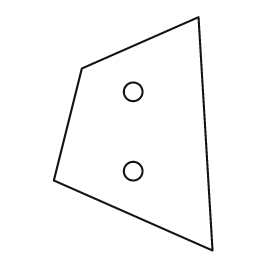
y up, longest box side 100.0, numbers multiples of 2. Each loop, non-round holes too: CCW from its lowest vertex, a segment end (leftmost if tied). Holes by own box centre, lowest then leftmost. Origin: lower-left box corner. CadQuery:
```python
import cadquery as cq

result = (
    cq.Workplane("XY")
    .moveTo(68.0, 0.0)
    .lineTo(62.0, 100.0)
    .lineTo(12.0, 78.0)
    .lineTo(0.0, 30.0)
    .close()
    .moveTo(34.0, 34.0)
    .circle(4.0)
    .moveTo(34.0, 68.0)
    .circle(4.0)
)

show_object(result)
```